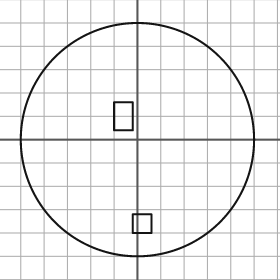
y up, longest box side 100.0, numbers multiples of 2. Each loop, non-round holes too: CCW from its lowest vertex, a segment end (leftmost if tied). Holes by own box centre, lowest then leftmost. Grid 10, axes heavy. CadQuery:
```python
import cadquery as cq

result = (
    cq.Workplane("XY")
    .moveTo(0.0, 0.0)
    .circle(50.0)
    .moveTo(-2.0, -40.0)
    .lineTo(6.0, -40.0)
    .lineTo(6.0, -32.0)
    .lineTo(-2.0, -32.0)
    .close()
    .moveTo(-10.0, 4.0)
    .lineTo(-2.0, 4.0)
    .lineTo(-2.0, 16.0)
    .lineTo(-10.0, 16.0)
    .close()
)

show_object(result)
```